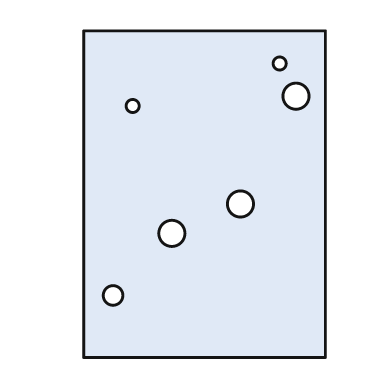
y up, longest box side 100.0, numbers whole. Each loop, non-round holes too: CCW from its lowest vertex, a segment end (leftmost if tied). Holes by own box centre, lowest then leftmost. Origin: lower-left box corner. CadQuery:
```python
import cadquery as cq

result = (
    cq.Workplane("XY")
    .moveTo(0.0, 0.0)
    .lineTo(74.0, 0.0)
    .lineTo(74.0, 100.0)
    .lineTo(0.0, 100.0)
    .close()
    .moveTo(9.0, 19.0)
    .circle(3.0)
    .moveTo(27.0, 38.0)
    .circle(4.0)
    .moveTo(48.0, 47.0)
    .circle(4.0)
    .moveTo(15.0, 77.0)
    .circle(2.0)
    .moveTo(65.0, 80.0)
    .circle(4.0)
    .moveTo(60.0, 90.0)
    .circle(2.0)
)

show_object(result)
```